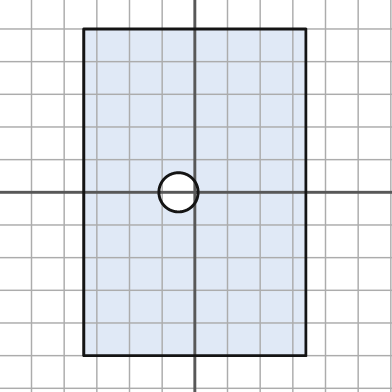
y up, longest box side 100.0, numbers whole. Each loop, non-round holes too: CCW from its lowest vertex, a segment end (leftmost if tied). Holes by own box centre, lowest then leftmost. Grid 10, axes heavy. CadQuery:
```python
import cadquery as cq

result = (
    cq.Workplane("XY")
    .moveTo(-34.0, -50.0)
    .lineTo(34.0, -50.0)
    .lineTo(34.0, 50.0)
    .lineTo(-34.0, 50.0)
    .close()
    .moveTo(-5.0, 0.0)
    .circle(6.0)
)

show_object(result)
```